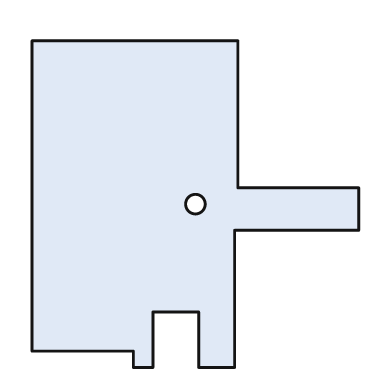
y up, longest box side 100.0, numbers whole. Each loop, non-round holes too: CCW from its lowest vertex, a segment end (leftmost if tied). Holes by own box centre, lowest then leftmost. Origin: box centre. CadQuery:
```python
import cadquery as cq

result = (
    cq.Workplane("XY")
    .moveTo(-19.0, -50.0)
    .lineTo(-13.0, -50.0)
    .lineTo(-13.0, -33.0)
    .lineTo(1.0, -33.0)
    .lineTo(1.0, -50.0)
    .lineTo(12.0, -50.0)
    .lineTo(12.0, -8.0)
    .lineTo(50.0, -8.0)
    .lineTo(50.0, 5.0)
    .lineTo(13.0, 5.0)
    .lineTo(13.0, 50.0)
    .lineTo(-50.0, 50.0)
    .lineTo(-50.0, -45.0)
    .lineTo(-19.0, -45.0)
    .close()
    .moveTo(0.0, 0.0)
    .circle(3.0)
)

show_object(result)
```